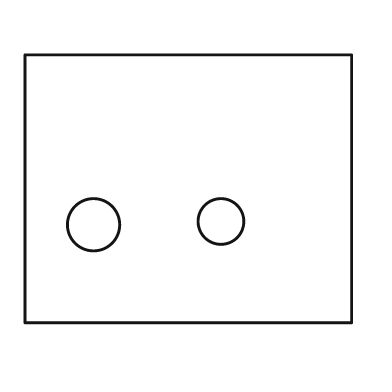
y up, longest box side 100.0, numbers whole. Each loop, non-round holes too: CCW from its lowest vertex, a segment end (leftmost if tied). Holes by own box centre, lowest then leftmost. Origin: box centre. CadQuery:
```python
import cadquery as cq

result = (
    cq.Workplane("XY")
    .moveTo(-50.0, -41.0)
    .lineTo(50.0, -41.0)
    .lineTo(50.0, 41.0)
    .lineTo(-50.0, 41.0)
    .close()
    .moveTo(-29.0, -11.0)
    .circle(8.0)
    .moveTo(10.0, -10.0)
    .circle(7.0)
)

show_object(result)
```